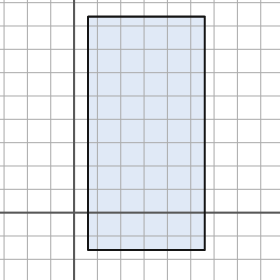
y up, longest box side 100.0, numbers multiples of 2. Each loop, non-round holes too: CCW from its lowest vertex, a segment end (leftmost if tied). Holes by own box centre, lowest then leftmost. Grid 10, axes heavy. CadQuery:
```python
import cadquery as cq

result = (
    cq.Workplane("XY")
    .moveTo(6.0, -16.0)
    .lineTo(56.0, -16.0)
    .lineTo(56.0, 84.0)
    .lineTo(6.0, 84.0)
    .close()
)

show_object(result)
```